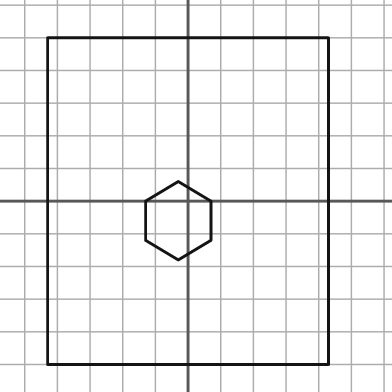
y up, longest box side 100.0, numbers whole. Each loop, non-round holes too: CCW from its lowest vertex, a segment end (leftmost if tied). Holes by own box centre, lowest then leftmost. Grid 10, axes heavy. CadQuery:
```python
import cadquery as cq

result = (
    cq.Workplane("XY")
    .moveTo(-43.0, -50.0)
    .lineTo(43.0, -50.0)
    .lineTo(43.0, 50.0)
    .lineTo(-43.0, 50.0)
    .close()
    .moveTo(-3.0, -18.0)
    .lineTo(7.0, -12.0)
    .lineTo(7.0, 0.0)
    .lineTo(-3.0, 6.0)
    .lineTo(-13.0, 0.0)
    .lineTo(-13.0, -12.0)
    .close()
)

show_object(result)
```